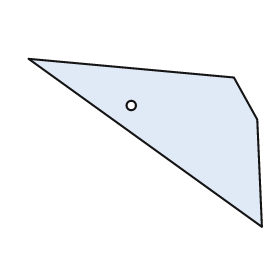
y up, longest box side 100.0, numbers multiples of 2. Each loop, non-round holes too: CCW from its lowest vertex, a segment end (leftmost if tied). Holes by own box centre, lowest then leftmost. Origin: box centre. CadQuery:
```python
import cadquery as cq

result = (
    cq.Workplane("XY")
    .moveTo(50.0, -36.0)
    .lineTo(48.0, 10.0)
    .lineTo(38.0, 28.0)
    .lineTo(-50.0, 36.0)
    .close()
    .moveTo(-6.0, 16.0)
    .circle(2.0)
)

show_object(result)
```